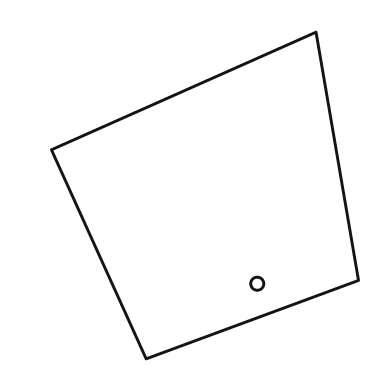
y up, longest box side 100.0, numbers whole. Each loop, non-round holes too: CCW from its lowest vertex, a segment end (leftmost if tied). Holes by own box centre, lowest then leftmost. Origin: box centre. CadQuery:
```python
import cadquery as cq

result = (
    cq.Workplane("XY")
    .moveTo(-18.0, -50.0)
    .lineTo(47.0, -26.0)
    .lineTo(34.0, 50.0)
    .lineTo(-47.0, 14.0)
    .close()
    .moveTo(16.0, -27.0)
    .circle(2.0)
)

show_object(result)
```